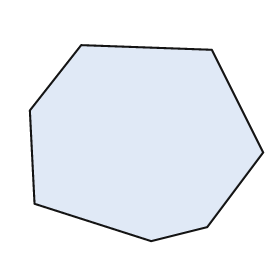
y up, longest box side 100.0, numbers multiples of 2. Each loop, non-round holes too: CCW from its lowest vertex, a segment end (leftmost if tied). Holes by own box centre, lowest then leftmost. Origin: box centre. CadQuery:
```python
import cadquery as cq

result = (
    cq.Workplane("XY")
    .moveTo(2.0, -42.0)
    .lineTo(26.0, -36.0)
    .lineTo(50.0, -4.0)
    .lineTo(28.0, 40.0)
    .lineTo(-28.0, 42.0)
    .lineTo(-50.0, 14.0)
    .lineTo(-48.0, -26.0)
    .close()
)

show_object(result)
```